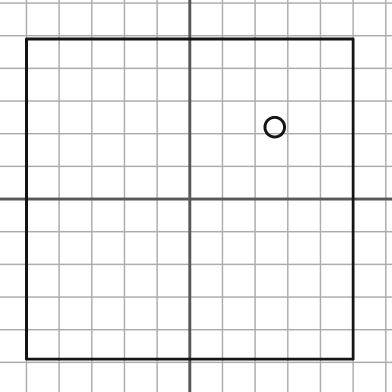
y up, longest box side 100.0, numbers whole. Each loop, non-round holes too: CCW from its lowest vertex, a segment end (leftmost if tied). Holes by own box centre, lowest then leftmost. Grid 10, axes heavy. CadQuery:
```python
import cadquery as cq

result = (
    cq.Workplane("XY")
    .moveTo(-50.0, -49.0)
    .lineTo(50.0, -49.0)
    .lineTo(50.0, 49.0)
    .lineTo(-50.0, 49.0)
    .close()
    .moveTo(26.0, 22.0)
    .circle(3.0)
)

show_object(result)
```